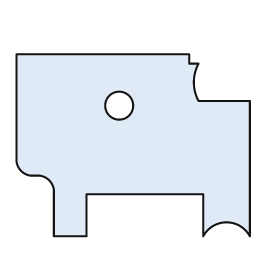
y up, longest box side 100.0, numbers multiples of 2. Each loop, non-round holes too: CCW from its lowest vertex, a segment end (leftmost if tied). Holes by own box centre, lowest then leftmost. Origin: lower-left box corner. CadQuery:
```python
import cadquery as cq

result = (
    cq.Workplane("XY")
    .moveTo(16.0, 0.0)
    .lineTo(30.0, 0.0)
    .lineTo(30.0, 18.0)
    .lineTo(80.0, 18.0)
    .lineTo(80.0, 0.0)
    .threePointArc((90.0, 6.0), (100.0, 0.0))
    .lineTo(100.0, 58.0)
    .lineTo(78.0, 58.0)
    .threePointArc((76.0, 66.0), (78.0, 74.0))
    .lineTo(74.0, 74.0)
    .lineTo(74.0, 78.0)
    .lineTo(0.0, 78.0)
    .lineTo(0.0, 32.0)
    .threePointArc((2.0, 28.0), (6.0, 26.0))
    .lineTo(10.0, 26.0)
    .threePointArc((14.0, 24.0), (16.0, 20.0))
    .close()
    .moveTo(44.0, 56.0)
    .circle(6.0)
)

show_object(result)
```